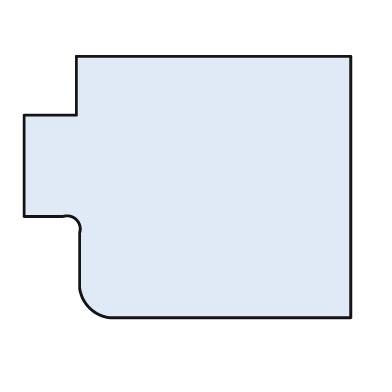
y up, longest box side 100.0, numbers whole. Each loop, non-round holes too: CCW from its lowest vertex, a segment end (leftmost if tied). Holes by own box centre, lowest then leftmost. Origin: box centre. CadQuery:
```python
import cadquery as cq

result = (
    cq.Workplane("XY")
    .moveTo(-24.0, -40.0)
    .lineTo(50.0, -40.0)
    .lineTo(50.0, 40.0)
    .lineTo(-34.0, 40.0)
    .lineTo(-34.0, 22.0)
    .lineTo(-50.0, 22.0)
    .lineTo(-50.0, -9.0)
    .lineTo(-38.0, -9.0)
    .threePointArc((-34.0, -10.0), (-33.0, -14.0))
    .lineTo(-33.0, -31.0)
    .threePointArc((-30.0, -37.0), (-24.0, -40.0))
    .close()
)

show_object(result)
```